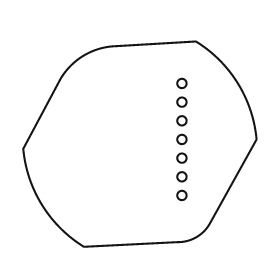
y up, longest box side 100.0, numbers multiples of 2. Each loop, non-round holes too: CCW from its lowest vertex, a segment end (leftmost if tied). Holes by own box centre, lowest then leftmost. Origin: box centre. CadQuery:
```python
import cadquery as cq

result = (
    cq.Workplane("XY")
    .moveTo(-24.0, -44.0)
    .lineTo(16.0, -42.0)
    .threePointArc((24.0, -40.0), (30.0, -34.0))
    .lineTo(50.0, 2.0)
    .threePointArc((42.0, 26.0), (24.0, 44.0))
    .lineTo(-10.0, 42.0)
    .threePointArc((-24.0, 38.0), (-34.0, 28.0))
    .lineTo(-50.0, -2.0)
    .threePointArc((-42.0, -26.0), (-24.0, -44.0))
    .close()
    .moveTo(18.0, -22.0)
    .circle(2.0)
    .moveTo(18.0, -14.0)
    .circle(2.0)
    .moveTo(18.0, -6.0)
    .circle(2.0)
    .moveTo(18.0, 2.0)
    .circle(2.0)
    .moveTo(18.0, 10.0)
    .circle(2.0)
    .moveTo(18.0, 18.0)
    .circle(2.0)
    .moveTo(18.0, 26.0)
    .circle(2.0)
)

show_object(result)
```